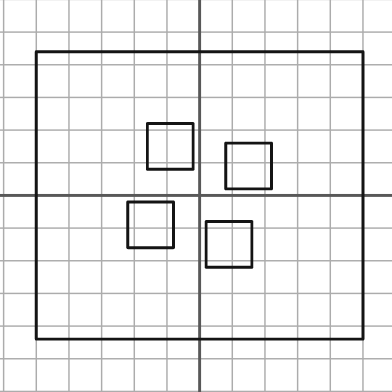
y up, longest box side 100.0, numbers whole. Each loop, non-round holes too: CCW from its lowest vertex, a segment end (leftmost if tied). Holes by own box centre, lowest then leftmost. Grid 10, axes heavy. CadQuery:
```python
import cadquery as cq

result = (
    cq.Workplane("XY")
    .moveTo(-50.0, -44.0)
    .lineTo(50.0, -44.0)
    .lineTo(50.0, 44.0)
    .lineTo(-50.0, 44.0)
    .close()
    .moveTo(2.0, -22.0)
    .lineTo(16.0, -22.0)
    .lineTo(16.0, -8.0)
    .lineTo(2.0, -8.0)
    .close()
    .moveTo(-22.0, -16.0)
    .lineTo(-8.0, -16.0)
    .lineTo(-8.0, -2.0)
    .lineTo(-22.0, -2.0)
    .close()
    .moveTo(8.0, 2.0)
    .lineTo(22.0, 2.0)
    .lineTo(22.0, 16.0)
    .lineTo(8.0, 16.0)
    .close()
    .moveTo(-16.0, 8.0)
    .lineTo(-2.0, 8.0)
    .lineTo(-2.0, 22.0)
    .lineTo(-16.0, 22.0)
    .close()
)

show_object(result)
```